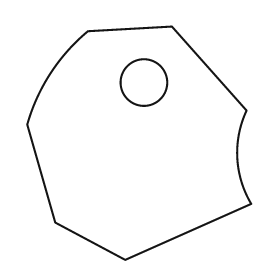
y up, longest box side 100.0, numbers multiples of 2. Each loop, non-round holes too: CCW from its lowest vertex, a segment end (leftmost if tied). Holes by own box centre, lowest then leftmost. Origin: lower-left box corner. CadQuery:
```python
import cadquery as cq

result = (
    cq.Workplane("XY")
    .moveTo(42.0, 0.0)
    .lineTo(96.0, 24.0)
    .threePointArc((90.0, 44.0), (94.0, 64.0))
    .lineTo(62.0, 100.0)
    .lineTo(26.0, 98.0)
    .threePointArc((10.0, 80.0), (0.0, 58.0))
    .lineTo(12.0, 16.0)
    .close()
    .moveTo(50.0, 76.0)
    .circle(10.0)
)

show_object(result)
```